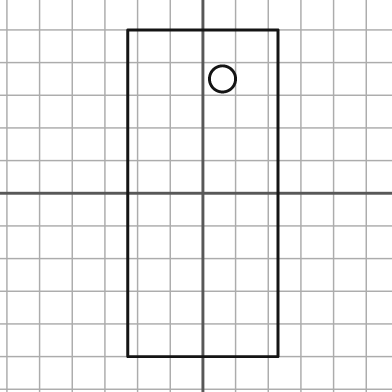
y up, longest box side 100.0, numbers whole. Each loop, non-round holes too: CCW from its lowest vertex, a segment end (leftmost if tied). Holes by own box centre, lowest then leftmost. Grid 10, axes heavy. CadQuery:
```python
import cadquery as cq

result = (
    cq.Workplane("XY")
    .moveTo(-23.0, -50.0)
    .lineTo(23.0, -50.0)
    .lineTo(23.0, 50.0)
    .lineTo(-23.0, 50.0)
    .close()
    .moveTo(6.0, 35.0)
    .circle(4.0)
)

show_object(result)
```